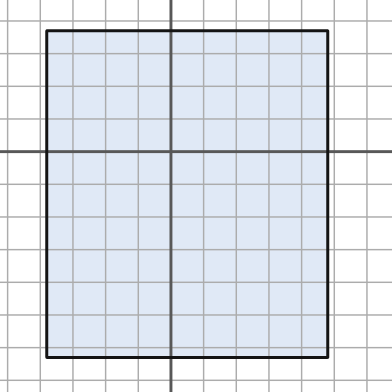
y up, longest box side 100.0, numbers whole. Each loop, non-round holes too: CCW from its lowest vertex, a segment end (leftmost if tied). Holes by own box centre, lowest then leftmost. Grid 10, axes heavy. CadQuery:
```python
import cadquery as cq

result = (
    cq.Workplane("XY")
    .moveTo(-38.0, -63.0)
    .lineTo(48.0, -63.0)
    .lineTo(48.0, 37.0)
    .lineTo(-38.0, 37.0)
    .close()
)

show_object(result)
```